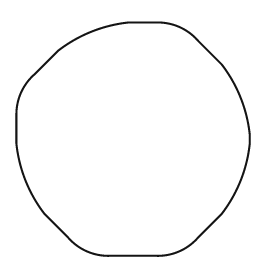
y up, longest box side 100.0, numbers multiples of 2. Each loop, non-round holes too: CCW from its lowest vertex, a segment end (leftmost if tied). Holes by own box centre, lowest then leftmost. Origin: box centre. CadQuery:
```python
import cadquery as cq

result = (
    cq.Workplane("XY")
    .moveTo(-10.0, -50.0)
    .lineTo(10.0, -50.0)
    .threePointArc((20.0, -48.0), (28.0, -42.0))
    .lineTo(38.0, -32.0)
    .threePointArc((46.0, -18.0), (50.0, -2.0))
    .lineTo(50.0, 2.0)
    .threePointArc((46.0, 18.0), (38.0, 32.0))
    .lineTo(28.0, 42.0)
    .threePointArc((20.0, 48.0), (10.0, 50.0))
    .lineTo(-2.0, 50.0)
    .threePointArc((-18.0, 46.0), (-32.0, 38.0))
    .lineTo(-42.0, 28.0)
    .threePointArc((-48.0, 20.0), (-50.0, 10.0))
    .lineTo(-50.0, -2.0)
    .threePointArc((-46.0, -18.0), (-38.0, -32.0))
    .lineTo(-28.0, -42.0)
    .threePointArc((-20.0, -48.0), (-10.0, -50.0))
    .close()
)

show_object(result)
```